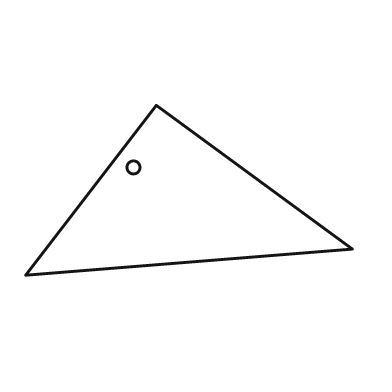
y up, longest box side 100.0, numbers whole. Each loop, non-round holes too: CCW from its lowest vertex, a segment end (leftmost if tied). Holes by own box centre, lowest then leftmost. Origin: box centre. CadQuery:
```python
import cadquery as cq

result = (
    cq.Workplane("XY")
    .moveTo(-50.0, -26.0)
    .lineTo(50.0, -18.0)
    .lineTo(-10.0, 26.0)
    .close()
    .moveTo(-17.0, 7.0)
    .circle(2.0)
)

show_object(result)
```